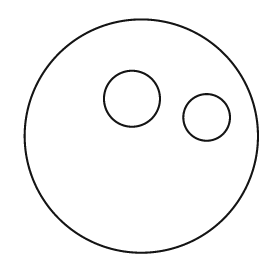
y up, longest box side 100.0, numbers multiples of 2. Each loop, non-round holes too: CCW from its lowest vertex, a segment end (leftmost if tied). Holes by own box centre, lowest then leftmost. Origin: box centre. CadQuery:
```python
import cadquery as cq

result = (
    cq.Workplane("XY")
    .moveTo(0.0, 0.0)
    .circle(50.0)
    .moveTo(28.0, 8.0)
    .circle(10.0)
    .moveTo(-4.0, 16.0)
    .circle(12.0)
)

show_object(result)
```